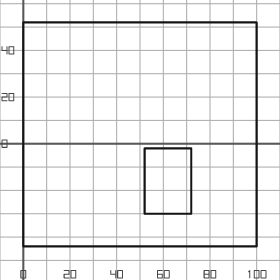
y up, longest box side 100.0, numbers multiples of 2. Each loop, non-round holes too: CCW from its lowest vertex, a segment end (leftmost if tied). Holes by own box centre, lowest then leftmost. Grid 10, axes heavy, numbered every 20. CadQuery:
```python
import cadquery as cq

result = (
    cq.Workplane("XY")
    .moveTo(0.0, -44.0)
    .lineTo(100.0, -44.0)
    .lineTo(100.0, 52.0)
    .lineTo(0.0, 52.0)
    .close()
    .moveTo(52.0, -30.0)
    .lineTo(72.0, -30.0)
    .lineTo(72.0, -2.0)
    .lineTo(52.0, -2.0)
    .close()
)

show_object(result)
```